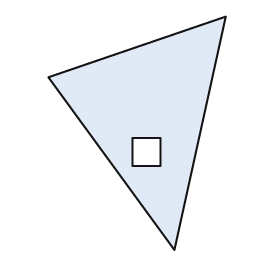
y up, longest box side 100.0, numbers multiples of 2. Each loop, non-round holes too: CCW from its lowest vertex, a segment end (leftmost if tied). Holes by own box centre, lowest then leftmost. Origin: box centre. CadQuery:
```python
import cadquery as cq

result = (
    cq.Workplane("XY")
    .moveTo(16.0, -50.0)
    .lineTo(38.0, 50.0)
    .lineTo(-38.0, 24.0)
    .close()
    .moveTo(-2.0, -14.0)
    .lineTo(10.0, -14.0)
    .lineTo(10.0, -2.0)
    .lineTo(-2.0, -2.0)
    .close()
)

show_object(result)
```